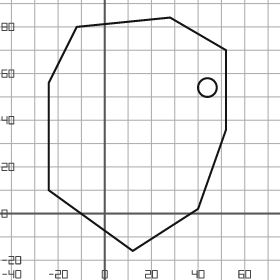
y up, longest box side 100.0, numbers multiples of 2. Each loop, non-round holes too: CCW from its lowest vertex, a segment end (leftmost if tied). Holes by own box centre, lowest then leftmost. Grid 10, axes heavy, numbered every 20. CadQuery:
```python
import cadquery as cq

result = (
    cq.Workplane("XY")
    .moveTo(12.0, -16.0)
    .lineTo(40.0, 2.0)
    .lineTo(52.0, 36.0)
    .lineTo(52.0, 70.0)
    .lineTo(28.0, 84.0)
    .lineTo(-12.0, 80.0)
    .lineTo(-24.0, 56.0)
    .lineTo(-24.0, 10.0)
    .close()
    .moveTo(44.0, 54.0)
    .circle(4.0)
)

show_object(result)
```